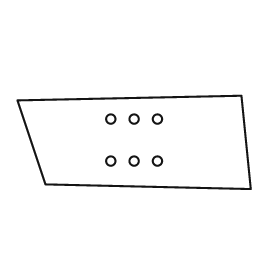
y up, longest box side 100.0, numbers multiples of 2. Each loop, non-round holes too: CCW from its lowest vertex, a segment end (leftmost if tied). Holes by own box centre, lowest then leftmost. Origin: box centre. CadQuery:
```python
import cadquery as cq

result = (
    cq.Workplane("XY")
    .moveTo(50.0, -20.0)
    .lineTo(46.0, 20.0)
    .lineTo(-50.0, 18.0)
    .lineTo(-38.0, -18.0)
    .close()
    .moveTo(-10.0, -8.0)
    .circle(2.0)
    .moveTo(0.0, -8.0)
    .circle(2.0)
    .moveTo(10.0, -8.0)
    .circle(2.0)
    .moveTo(-10.0, 10.0)
    .circle(2.0)
    .moveTo(0.0, 10.0)
    .circle(2.0)
    .moveTo(10.0, 10.0)
    .circle(2.0)
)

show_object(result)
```